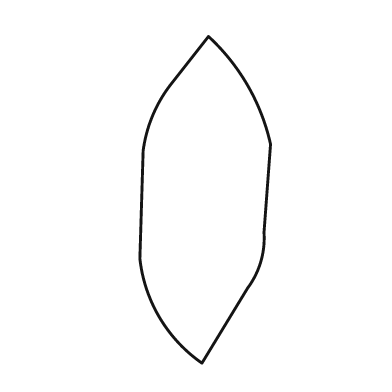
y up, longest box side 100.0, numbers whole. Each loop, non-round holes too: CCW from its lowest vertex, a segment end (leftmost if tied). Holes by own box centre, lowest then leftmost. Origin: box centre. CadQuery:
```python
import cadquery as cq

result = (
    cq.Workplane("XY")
    .moveTo(-1.0, -50.0)
    .lineTo(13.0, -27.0)
    .threePointArc((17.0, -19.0), (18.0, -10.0))
    .lineTo(20.0, 17.0)
    .threePointArc((13.0, 35.0), (1.0, 50.0))
    .lineTo(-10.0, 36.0)
    .threePointArc((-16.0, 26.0), (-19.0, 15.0))
    .lineTo(-20.0, -18.0)
    .threePointArc((-14.0, -36.0), (-1.0, -50.0))
    .close()
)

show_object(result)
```